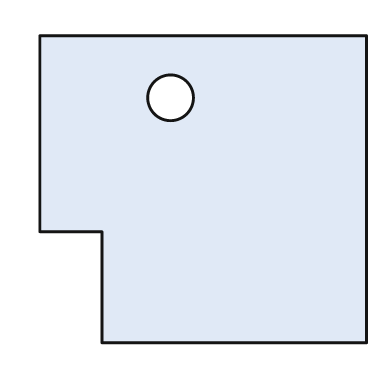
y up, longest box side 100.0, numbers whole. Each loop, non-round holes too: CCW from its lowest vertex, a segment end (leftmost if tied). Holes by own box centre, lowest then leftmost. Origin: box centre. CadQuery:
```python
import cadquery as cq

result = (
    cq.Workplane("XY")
    .moveTo(-31.0, -47.0)
    .lineTo(50.0, -47.0)
    .lineTo(50.0, 47.0)
    .lineTo(-50.0, 47.0)
    .lineTo(-50.0, -13.0)
    .lineTo(-31.0, -13.0)
    .close()
    .moveTo(-10.0, 28.0)
    .circle(7.0)
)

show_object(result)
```